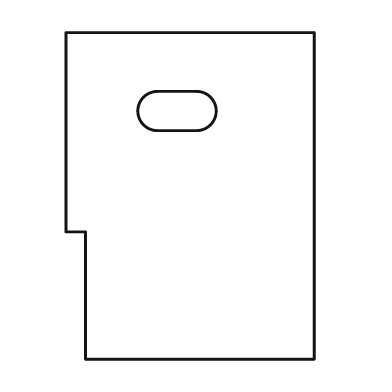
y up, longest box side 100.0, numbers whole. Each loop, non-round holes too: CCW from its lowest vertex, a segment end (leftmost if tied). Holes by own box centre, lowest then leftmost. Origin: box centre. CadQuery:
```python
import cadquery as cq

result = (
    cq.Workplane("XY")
    .moveTo(-32.0, -50.0)
    .lineTo(38.0, -50.0)
    .lineTo(38.0, 50.0)
    .lineTo(-38.0, 50.0)
    .lineTo(-38.0, -11.0)
    .lineTo(-32.0, -11.0)
    .close()
    .moveTo(-10.0, 20.0)
    .lineTo(2.0, 20.0)
    .threePointArc((8.0, 26.0), (2.0, 32.0))
    .lineTo(-10.0, 32.0)
    .threePointArc((-16.0, 26.0), (-10.0, 20.0))
    .close()
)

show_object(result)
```